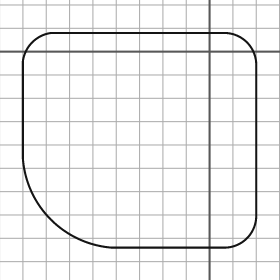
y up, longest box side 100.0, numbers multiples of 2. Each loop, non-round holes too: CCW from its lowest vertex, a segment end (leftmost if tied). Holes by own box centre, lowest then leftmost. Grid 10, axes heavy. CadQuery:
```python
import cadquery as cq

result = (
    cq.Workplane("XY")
    .moveTo(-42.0, -84.0)
    .lineTo(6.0, -84.0)
    .threePointArc((16.0, -80.0), (20.0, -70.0))
    .lineTo(20.0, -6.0)
    .threePointArc((16.0, 4.0), (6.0, 8.0))
    .lineTo(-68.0, 8.0)
    .threePointArc((-76.0, 4.0), (-80.0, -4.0))
    .lineTo(-80.0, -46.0)
    .threePointArc((-68.0, -72.0), (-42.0, -84.0))
    .close()
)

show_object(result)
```